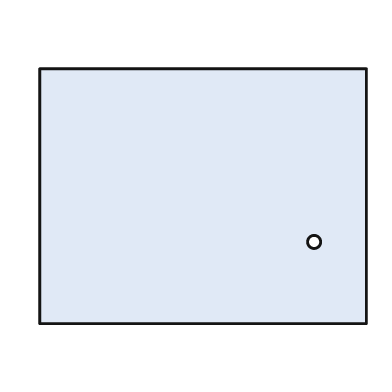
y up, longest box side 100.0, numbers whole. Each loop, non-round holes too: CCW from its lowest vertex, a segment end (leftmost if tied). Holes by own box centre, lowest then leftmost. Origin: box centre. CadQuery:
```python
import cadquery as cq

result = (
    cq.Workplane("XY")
    .moveTo(-50.0, -39.0)
    .lineTo(50.0, -39.0)
    .lineTo(50.0, 39.0)
    .lineTo(-50.0, 39.0)
    .close()
    .moveTo(34.0, -14.0)
    .circle(2.0)
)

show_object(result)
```